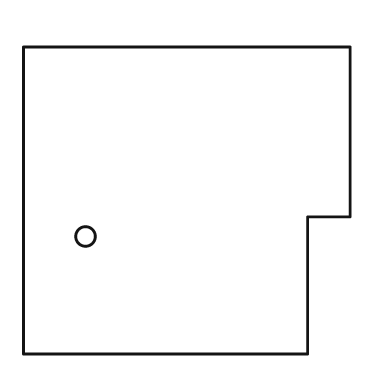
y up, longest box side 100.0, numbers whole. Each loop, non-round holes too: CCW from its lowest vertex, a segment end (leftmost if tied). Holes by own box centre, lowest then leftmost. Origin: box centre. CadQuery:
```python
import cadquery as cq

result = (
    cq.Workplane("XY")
    .moveTo(-50.0, -47.0)
    .lineTo(37.0, -47.0)
    .lineTo(37.0, -5.0)
    .lineTo(50.0, -5.0)
    .lineTo(50.0, 47.0)
    .lineTo(-50.0, 47.0)
    .close()
    .moveTo(-31.0, -11.0)
    .circle(3.0)
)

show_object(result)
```